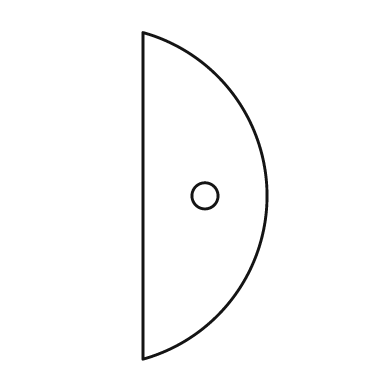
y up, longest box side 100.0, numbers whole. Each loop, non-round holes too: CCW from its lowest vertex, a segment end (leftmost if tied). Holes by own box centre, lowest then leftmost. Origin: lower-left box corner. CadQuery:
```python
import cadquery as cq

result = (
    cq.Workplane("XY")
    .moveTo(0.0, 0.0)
    .threePointArc((38.0, 50.0), (0.0, 100.0))
    .close()
    .moveTo(19.0, 50.0)
    .circle(4.0)
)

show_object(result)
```